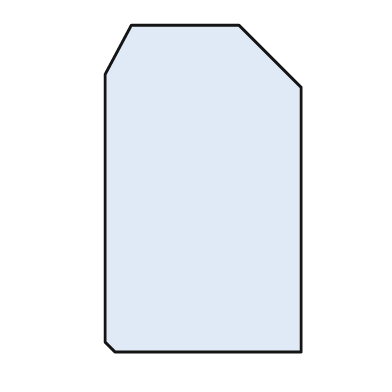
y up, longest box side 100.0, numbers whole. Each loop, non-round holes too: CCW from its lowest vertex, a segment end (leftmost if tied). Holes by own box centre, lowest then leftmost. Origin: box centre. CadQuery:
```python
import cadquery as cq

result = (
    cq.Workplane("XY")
    .moveTo(-27.0, -50.0)
    .lineTo(30.0, -50.0)
    .lineTo(30.0, 31.0)
    .lineTo(11.0, 50.0)
    .lineTo(-22.0, 50.0)
    .lineTo(-30.0, 35.0)
    .lineTo(-30.0, -47.0)
    .close()
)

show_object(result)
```